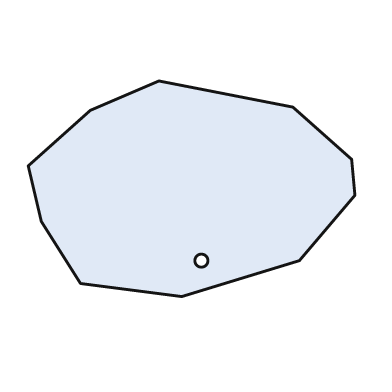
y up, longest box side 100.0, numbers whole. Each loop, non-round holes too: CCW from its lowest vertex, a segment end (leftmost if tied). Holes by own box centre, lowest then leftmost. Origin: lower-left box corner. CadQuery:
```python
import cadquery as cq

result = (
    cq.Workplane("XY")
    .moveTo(47.0, 0.0)
    .lineTo(83.0, 11.0)
    .lineTo(100.0, 31.0)
    .lineTo(99.0, 42.0)
    .lineTo(81.0, 58.0)
    .lineTo(40.0, 66.0)
    .lineTo(19.0, 57.0)
    .lineTo(0.0, 40.0)
    .lineTo(4.0, 23.0)
    .lineTo(16.0, 4.0)
    .close()
    .moveTo(53.0, 11.0)
    .circle(2.0)
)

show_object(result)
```